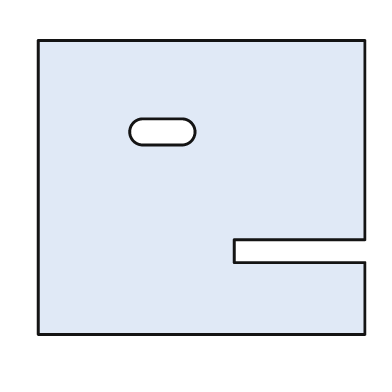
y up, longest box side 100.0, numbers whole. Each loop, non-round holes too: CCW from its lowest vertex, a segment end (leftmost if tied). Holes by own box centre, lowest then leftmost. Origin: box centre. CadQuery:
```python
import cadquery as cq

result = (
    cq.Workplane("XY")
    .moveTo(-50.0, -45.0)
    .lineTo(50.0, -45.0)
    .lineTo(50.0, -23.0)
    .lineTo(10.0, -23.0)
    .lineTo(10.0, -16.0)
    .lineTo(50.0, -16.0)
    .lineTo(50.0, 45.0)
    .lineTo(-50.0, 45.0)
    .close()
    .moveTo(-18.0, 13.0)
    .lineTo(-6.0, 13.0)
    .threePointArc((-2.0, 17.0), (-6.0, 21.0))
    .lineTo(-18.0, 21.0)
    .threePointArc((-22.0, 17.0), (-18.0, 13.0))
    .close()
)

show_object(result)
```